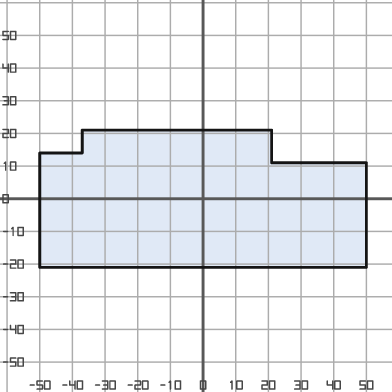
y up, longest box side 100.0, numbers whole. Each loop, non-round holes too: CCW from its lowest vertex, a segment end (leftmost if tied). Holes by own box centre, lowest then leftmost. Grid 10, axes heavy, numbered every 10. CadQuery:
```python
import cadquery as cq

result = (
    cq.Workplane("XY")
    .moveTo(-50.0, -21.0)
    .lineTo(50.0, -21.0)
    .lineTo(50.0, 11.0)
    .lineTo(21.0, 11.0)
    .lineTo(21.0, 21.0)
    .lineTo(-37.0, 21.0)
    .lineTo(-37.0, 14.0)
    .lineTo(-50.0, 14.0)
    .close()
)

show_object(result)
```